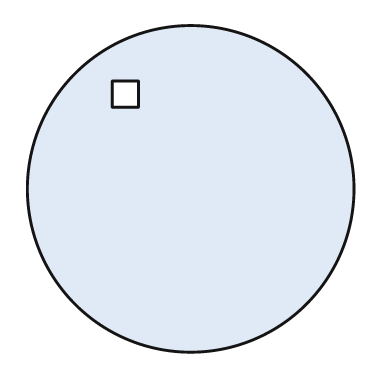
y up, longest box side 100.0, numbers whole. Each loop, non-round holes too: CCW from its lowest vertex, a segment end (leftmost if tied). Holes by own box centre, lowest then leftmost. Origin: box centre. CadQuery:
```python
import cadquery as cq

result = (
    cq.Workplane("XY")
    .moveTo(0.0, 0.0)
    .circle(50.0)
    .moveTo(-24.0, 25.0)
    .lineTo(-16.0, 25.0)
    .lineTo(-16.0, 33.0)
    .lineTo(-24.0, 33.0)
    .close()
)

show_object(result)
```